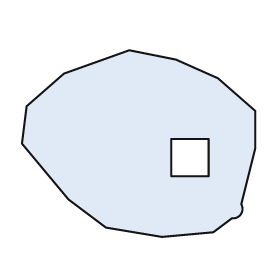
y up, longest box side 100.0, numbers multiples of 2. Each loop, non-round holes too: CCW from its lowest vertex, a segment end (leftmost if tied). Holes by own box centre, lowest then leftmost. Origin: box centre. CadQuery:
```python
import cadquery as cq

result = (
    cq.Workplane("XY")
    .moveTo(10.0, -40.0)
    .lineTo(32.0, -38.0)
    .lineTo(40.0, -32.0)
    .threePointArc((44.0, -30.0), (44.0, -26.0))
    .lineTo(50.0, -2.0)
    .lineTo(50.0, 14.0)
    .lineTo(34.0, 28.0)
    .lineTo(16.0, 36.0)
    .lineTo(-4.0, 40.0)
    .lineTo(-32.0, 30.0)
    .lineTo(-48.0, 16.0)
    .lineTo(-50.0, 0.0)
    .lineTo(-30.0, -24.0)
    .lineTo(-14.0, -36.0)
    .close()
    .moveTo(14.0, -14.0)
    .lineTo(30.0, -14.0)
    .lineTo(30.0, 2.0)
    .lineTo(14.0, 2.0)
    .close()
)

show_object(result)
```